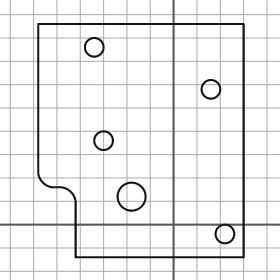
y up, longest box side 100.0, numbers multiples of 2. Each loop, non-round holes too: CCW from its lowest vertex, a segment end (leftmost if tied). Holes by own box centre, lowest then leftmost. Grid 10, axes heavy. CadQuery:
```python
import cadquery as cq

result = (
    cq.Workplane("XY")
    .moveTo(-42.0, -14.0)
    .lineTo(30.0, -14.0)
    .lineTo(30.0, 86.0)
    .lineTo(-58.0, 86.0)
    .lineTo(-58.0, 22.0)
    .threePointArc((-56.0, 18.0), (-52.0, 16.0))
    .lineTo(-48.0, 16.0)
    .threePointArc((-44.0, 14.0), (-42.0, 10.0))
    .close()
    .moveTo(22.0, -4.0)
    .circle(4.0)
    .moveTo(-18.0, 12.0)
    .circle(6.0)
    .moveTo(-30.0, 36.0)
    .circle(4.0)
    .moveTo(16.0, 58.0)
    .circle(4.0)
    .moveTo(-34.0, 76.0)
    .circle(4.0)
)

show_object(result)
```